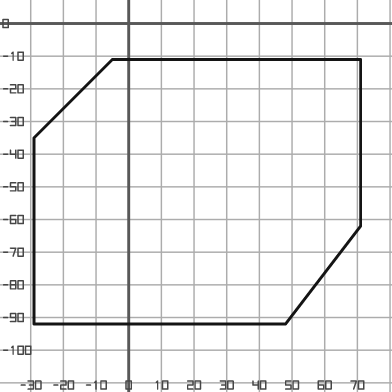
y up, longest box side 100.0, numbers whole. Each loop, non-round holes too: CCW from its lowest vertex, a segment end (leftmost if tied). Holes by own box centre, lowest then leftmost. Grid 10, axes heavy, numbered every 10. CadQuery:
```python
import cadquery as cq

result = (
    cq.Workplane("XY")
    .moveTo(-29.0, -92.0)
    .lineTo(48.0, -92.0)
    .lineTo(71.0, -62.0)
    .lineTo(71.0, -11.0)
    .lineTo(-5.0, -11.0)
    .lineTo(-29.0, -35.0)
    .close()
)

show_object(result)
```